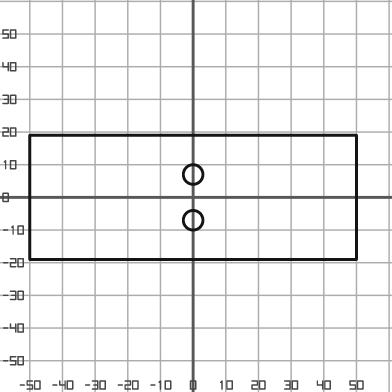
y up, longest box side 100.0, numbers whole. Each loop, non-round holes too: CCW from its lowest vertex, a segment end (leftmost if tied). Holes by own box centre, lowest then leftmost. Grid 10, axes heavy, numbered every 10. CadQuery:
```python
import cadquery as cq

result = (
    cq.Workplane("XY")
    .moveTo(-50.0, -19.0)
    .lineTo(50.0, -19.0)
    .lineTo(50.0, 19.0)
    .lineTo(-50.0, 19.0)
    .close()
    .moveTo(0.0, -7.0)
    .circle(3.0)
    .moveTo(0.0, 7.0)
    .circle(3.0)
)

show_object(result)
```